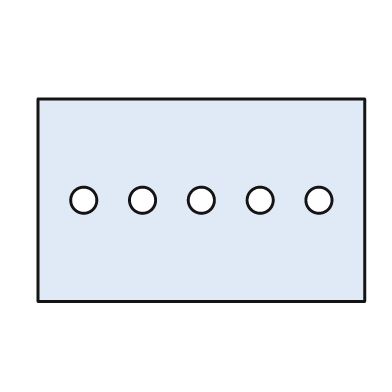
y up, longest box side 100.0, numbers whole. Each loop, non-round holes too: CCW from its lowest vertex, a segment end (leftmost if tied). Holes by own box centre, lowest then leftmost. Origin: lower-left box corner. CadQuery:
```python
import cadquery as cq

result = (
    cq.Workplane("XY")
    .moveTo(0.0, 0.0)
    .lineTo(100.0, 0.0)
    .lineTo(100.0, 62.0)
    .lineTo(0.0, 62.0)
    .close()
    .moveTo(14.0, 31.0)
    .circle(4.0)
    .moveTo(32.0, 31.0)
    .circle(4.0)
    .moveTo(50.0, 31.0)
    .circle(4.0)
    .moveTo(68.0, 31.0)
    .circle(4.0)
    .moveTo(86.0, 31.0)
    .circle(4.0)
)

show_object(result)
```